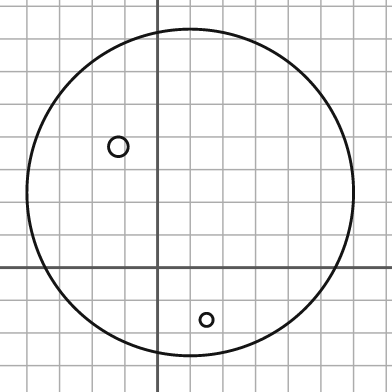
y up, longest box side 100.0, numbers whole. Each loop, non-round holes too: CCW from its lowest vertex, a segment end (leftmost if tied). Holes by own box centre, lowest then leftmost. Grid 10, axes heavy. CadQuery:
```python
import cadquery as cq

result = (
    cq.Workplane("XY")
    .moveTo(10.0, 23.0)
    .circle(50.0)
    .moveTo(15.0, -16.0)
    .circle(2.0)
    .moveTo(-12.0, 37.0)
    .circle(3.0)
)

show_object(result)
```